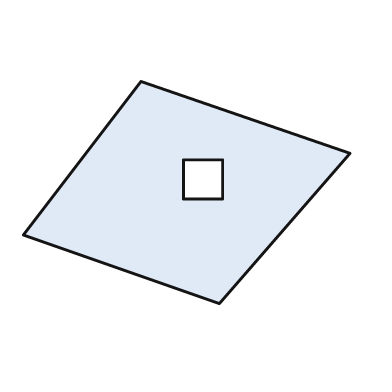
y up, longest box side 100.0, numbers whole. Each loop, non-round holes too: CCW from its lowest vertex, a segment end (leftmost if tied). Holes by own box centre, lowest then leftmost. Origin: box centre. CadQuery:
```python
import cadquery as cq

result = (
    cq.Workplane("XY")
    .moveTo(10.0, -34.0)
    .lineTo(50.0, 12.0)
    .lineTo(-14.0, 34.0)
    .lineTo(-50.0, -13.0)
    .close()
    .moveTo(-1.0, -2.0)
    .lineTo(11.0, -2.0)
    .lineTo(11.0, 10.0)
    .lineTo(-1.0, 10.0)
    .close()
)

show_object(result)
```